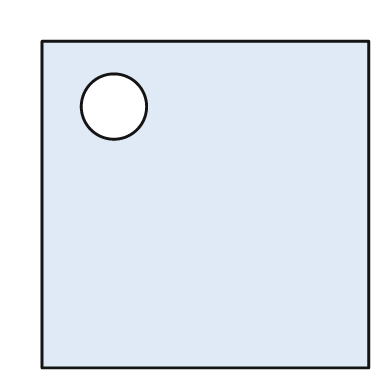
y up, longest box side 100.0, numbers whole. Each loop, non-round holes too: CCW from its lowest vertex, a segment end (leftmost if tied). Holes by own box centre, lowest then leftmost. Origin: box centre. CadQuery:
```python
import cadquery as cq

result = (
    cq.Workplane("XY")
    .moveTo(-50.0, -50.0)
    .lineTo(50.0, -50.0)
    .lineTo(50.0, 50.0)
    .lineTo(-50.0, 50.0)
    .close()
    .moveTo(-28.0, 30.0)
    .circle(10.0)
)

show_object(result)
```